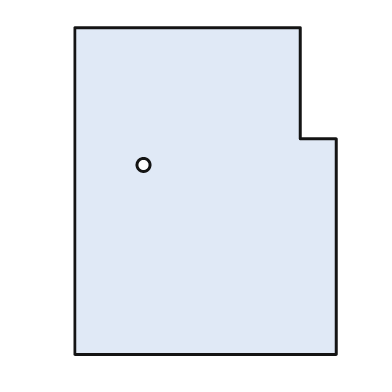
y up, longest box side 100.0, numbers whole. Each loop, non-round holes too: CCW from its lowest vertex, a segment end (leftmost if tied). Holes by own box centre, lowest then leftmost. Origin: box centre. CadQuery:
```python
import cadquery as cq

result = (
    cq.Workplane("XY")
    .moveTo(-40.0, -50.0)
    .lineTo(40.0, -50.0)
    .lineTo(40.0, 16.0)
    .lineTo(29.0, 16.0)
    .lineTo(29.0, 50.0)
    .lineTo(-40.0, 50.0)
    .close()
    .moveTo(-19.0, 8.0)
    .circle(2.0)
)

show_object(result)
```